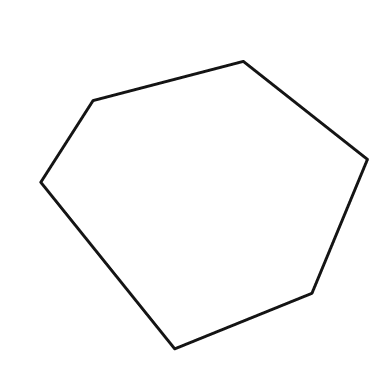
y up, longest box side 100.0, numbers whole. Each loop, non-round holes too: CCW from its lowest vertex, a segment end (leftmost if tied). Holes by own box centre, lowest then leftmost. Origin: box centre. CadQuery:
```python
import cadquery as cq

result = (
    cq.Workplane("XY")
    .moveTo(-9.0, -44.0)
    .lineTo(33.0, -27.0)
    .lineTo(50.0, 14.0)
    .lineTo(12.0, 44.0)
    .lineTo(-34.0, 32.0)
    .lineTo(-50.0, 7.0)
    .close()
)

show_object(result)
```